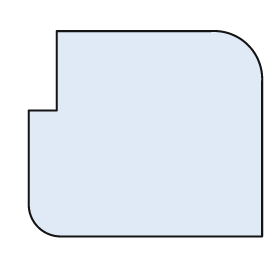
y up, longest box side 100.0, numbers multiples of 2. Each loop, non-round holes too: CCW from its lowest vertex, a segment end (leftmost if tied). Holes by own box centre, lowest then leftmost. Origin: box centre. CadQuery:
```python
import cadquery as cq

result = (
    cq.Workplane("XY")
    .moveTo(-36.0, -44.0)
    .lineTo(50.0, -44.0)
    .lineTo(50.0, 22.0)
    .threePointArc((44.0, 38.0), (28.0, 44.0))
    .lineTo(-38.0, 44.0)
    .lineTo(-38.0, 10.0)
    .lineTo(-50.0, 10.0)
    .lineTo(-50.0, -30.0)
    .threePointArc((-46.0, -40.0), (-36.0, -44.0))
    .close()
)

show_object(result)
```